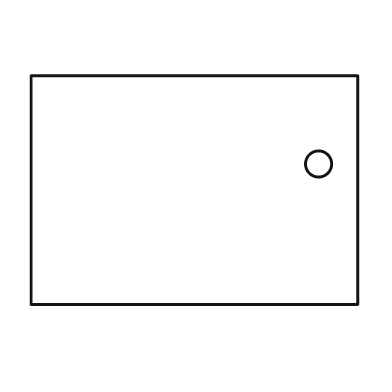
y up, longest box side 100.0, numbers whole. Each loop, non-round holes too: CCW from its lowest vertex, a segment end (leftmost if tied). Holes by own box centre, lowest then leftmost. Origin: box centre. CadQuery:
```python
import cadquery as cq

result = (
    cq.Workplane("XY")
    .moveTo(-50.0, -35.0)
    .lineTo(50.0, -35.0)
    .lineTo(50.0, 35.0)
    .lineTo(-50.0, 35.0)
    .close()
    .moveTo(38.0, 8.0)
    .circle(4.0)
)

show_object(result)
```